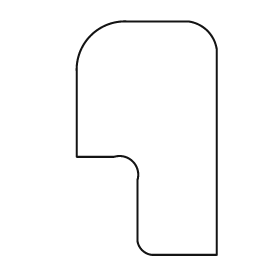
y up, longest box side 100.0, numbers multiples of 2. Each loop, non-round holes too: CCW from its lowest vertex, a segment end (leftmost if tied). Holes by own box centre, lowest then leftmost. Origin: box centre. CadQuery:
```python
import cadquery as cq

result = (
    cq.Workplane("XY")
    .moveTo(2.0, -50.0)
    .lineTo(30.0, -50.0)
    .lineTo(30.0, 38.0)
    .threePointArc((26.0, 46.0), (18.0, 50.0))
    .lineTo(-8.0, 50.0)
    .threePointArc((-24.0, 44.0), (-30.0, 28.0))
    .lineTo(-30.0, -8.0)
    .lineTo(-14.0, -8.0)
    .threePointArc((-6.0, -10.0), (-4.0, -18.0))
    .lineTo(-4.0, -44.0)
    .threePointArc((-2.0, -48.0), (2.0, -50.0))
    .close()
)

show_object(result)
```